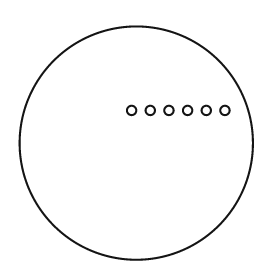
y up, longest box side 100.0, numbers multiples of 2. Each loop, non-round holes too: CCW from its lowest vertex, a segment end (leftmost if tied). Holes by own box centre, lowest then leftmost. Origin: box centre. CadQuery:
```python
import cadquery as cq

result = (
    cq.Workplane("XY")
    .moveTo(0.0, 0.0)
    .circle(50.0)
    .moveTo(-2.0, 14.0)
    .circle(2.0)
    .moveTo(6.0, 14.0)
    .circle(2.0)
    .moveTo(14.0, 14.0)
    .circle(2.0)
    .moveTo(22.0, 14.0)
    .circle(2.0)
    .moveTo(30.0, 14.0)
    .circle(2.0)
    .moveTo(38.0, 14.0)
    .circle(2.0)
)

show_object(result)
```